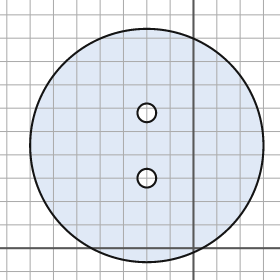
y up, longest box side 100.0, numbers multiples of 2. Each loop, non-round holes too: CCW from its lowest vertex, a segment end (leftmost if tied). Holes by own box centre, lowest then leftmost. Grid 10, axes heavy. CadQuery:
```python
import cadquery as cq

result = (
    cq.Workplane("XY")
    .moveTo(-20.0, 44.0)
    .circle(50.0)
    .moveTo(-20.0, 30.0)
    .circle(4.0)
    .moveTo(-20.0, 58.0)
    .circle(4.0)
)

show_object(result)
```